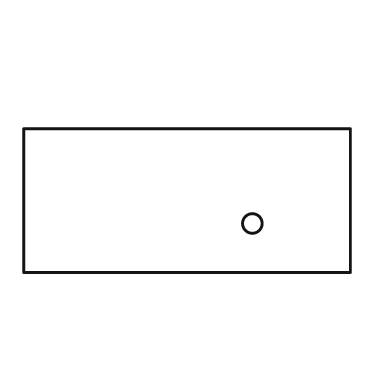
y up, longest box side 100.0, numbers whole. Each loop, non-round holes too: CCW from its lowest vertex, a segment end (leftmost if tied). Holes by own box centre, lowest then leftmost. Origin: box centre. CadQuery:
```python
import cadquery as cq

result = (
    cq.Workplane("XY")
    .moveTo(-50.0, -22.0)
    .lineTo(50.0, -22.0)
    .lineTo(50.0, 22.0)
    .lineTo(-50.0, 22.0)
    .close()
    .moveTo(20.0, -7.0)
    .circle(3.0)
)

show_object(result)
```